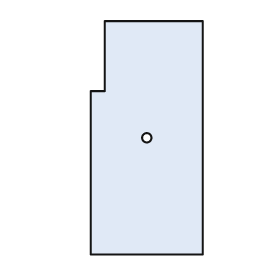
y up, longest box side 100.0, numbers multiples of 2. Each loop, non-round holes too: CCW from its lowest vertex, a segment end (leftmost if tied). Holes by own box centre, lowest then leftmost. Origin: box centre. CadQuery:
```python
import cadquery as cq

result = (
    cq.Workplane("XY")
    .moveTo(-24.0, -50.0)
    .lineTo(24.0, -50.0)
    .lineTo(24.0, 50.0)
    .lineTo(-18.0, 50.0)
    .lineTo(-18.0, 20.0)
    .lineTo(-24.0, 20.0)
    .close()
    .moveTo(0.0, 0.0)
    .circle(2.0)
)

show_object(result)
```